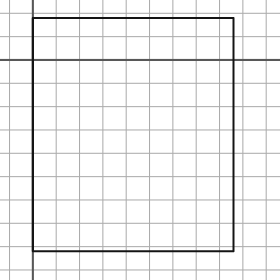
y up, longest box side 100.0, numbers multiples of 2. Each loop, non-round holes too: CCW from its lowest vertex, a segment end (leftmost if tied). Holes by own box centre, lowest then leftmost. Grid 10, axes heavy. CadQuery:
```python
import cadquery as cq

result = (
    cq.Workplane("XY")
    .moveTo(0.0, -82.0)
    .lineTo(86.0, -82.0)
    .lineTo(86.0, 18.0)
    .lineTo(0.0, 18.0)
    .close()
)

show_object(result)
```